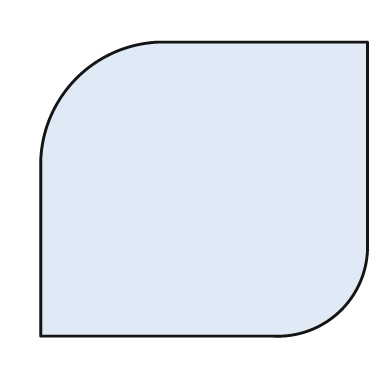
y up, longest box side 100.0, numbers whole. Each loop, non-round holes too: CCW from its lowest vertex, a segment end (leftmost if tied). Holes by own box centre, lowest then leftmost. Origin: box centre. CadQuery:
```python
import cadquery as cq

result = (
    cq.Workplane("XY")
    .moveTo(-50.0, -45.0)
    .lineTo(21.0, -45.0)
    .threePointArc((42.0, -37.0), (50.0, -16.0))
    .lineTo(50.0, 45.0)
    .lineTo(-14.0, 45.0)
    .threePointArc((-39.0, 34.0), (-50.0, 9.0))
    .close()
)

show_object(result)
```